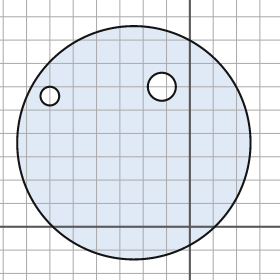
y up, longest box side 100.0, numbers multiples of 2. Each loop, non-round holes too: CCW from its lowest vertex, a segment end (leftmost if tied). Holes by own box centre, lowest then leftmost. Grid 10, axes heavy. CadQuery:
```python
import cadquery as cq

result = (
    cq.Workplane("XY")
    .moveTo(-24.0, 36.0)
    .circle(50.0)
    .moveTo(-60.0, 56.0)
    .circle(4.0)
    .moveTo(-12.0, 60.0)
    .circle(6.0)
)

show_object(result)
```